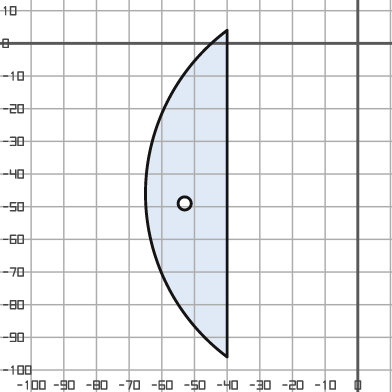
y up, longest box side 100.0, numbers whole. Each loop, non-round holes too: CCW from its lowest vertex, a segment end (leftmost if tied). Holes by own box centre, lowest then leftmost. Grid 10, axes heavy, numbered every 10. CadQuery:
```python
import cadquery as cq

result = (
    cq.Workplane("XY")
    .moveTo(-40.0, -96.0)
    .lineTo(-40.0, 4.0)
    .threePointArc((-65.0, -46.0), (-40.0, -96.0))
    .close()
    .moveTo(-53.0, -49.0)
    .circle(2.0)
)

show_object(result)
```